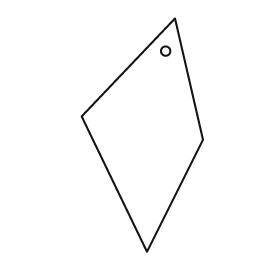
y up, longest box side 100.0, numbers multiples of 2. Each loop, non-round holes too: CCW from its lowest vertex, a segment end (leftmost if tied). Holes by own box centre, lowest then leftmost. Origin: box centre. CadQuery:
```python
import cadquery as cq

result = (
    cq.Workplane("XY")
    .moveTo(2.0, -50.0)
    .lineTo(26.0, -2.0)
    .lineTo(14.0, 50.0)
    .lineTo(-26.0, 8.0)
    .close()
    .moveTo(10.0, 36.0)
    .circle(2.0)
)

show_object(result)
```